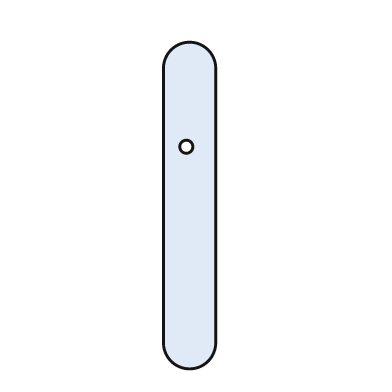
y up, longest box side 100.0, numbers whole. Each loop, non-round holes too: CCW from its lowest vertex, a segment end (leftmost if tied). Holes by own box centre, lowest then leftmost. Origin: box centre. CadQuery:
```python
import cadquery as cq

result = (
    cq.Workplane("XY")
    .moveTo(-8.0, -42.0)
    .threePointArc((0.0, -50.0), (8.0, -42.0))
    .lineTo(8.0, 42.0)
    .threePointArc((0.0, 50.0), (-8.0, 42.0))
    .close()
    .moveTo(-1.0, 18.0)
    .circle(2.0)
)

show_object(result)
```